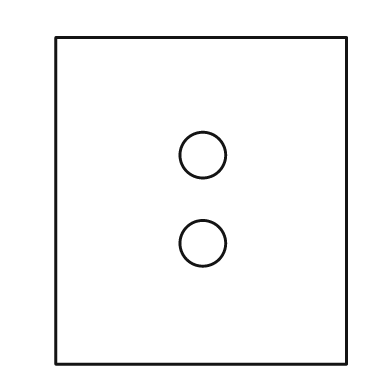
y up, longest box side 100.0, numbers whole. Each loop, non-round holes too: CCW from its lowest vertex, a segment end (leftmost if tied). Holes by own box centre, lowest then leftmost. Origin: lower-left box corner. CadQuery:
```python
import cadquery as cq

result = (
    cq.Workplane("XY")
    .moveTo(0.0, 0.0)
    .lineTo(89.0, 0.0)
    .lineTo(89.0, 100.0)
    .lineTo(0.0, 100.0)
    .close()
    .moveTo(45.0, 37.0)
    .circle(7.0)
    .moveTo(45.0, 64.0)
    .circle(7.0)
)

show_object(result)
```